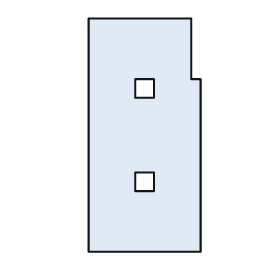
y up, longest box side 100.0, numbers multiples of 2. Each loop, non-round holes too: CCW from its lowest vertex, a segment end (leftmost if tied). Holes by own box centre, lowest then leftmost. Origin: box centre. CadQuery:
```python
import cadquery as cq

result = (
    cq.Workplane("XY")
    .moveTo(-24.0, -50.0)
    .lineTo(24.0, -50.0)
    .lineTo(24.0, 24.0)
    .lineTo(20.0, 24.0)
    .lineTo(20.0, 50.0)
    .lineTo(-24.0, 50.0)
    .close()
    .moveTo(-4.0, -24.0)
    .lineTo(4.0, -24.0)
    .lineTo(4.0, -16.0)
    .lineTo(-4.0, -16.0)
    .close()
    .moveTo(-4.0, 16.0)
    .lineTo(4.0, 16.0)
    .lineTo(4.0, 24.0)
    .lineTo(-4.0, 24.0)
    .close()
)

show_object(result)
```